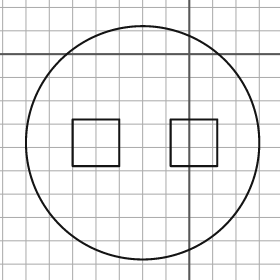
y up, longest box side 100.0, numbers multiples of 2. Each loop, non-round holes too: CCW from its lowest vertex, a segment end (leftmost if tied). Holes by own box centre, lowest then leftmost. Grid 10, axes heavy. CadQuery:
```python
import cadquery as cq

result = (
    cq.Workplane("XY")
    .moveTo(-20.0, -38.0)
    .circle(50.0)
    .moveTo(-50.0, -48.0)
    .lineTo(-30.0, -48.0)
    .lineTo(-30.0, -28.0)
    .lineTo(-50.0, -28.0)
    .close()
    .moveTo(-8.0, -48.0)
    .lineTo(12.0, -48.0)
    .lineTo(12.0, -28.0)
    .lineTo(-8.0, -28.0)
    .close()
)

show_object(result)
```